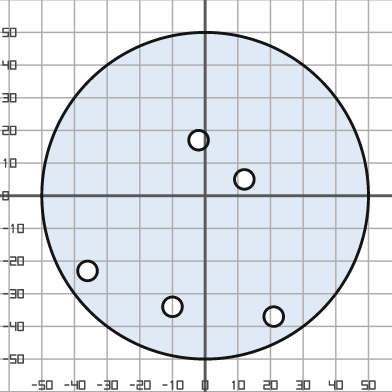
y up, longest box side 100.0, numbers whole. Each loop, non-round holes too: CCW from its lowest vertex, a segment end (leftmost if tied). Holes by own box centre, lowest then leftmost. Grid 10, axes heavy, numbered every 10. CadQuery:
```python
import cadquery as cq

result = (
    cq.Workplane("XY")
    .moveTo(0.0, 0.0)
    .circle(50.0)
    .moveTo(21.0, -37.0)
    .circle(3.0)
    .moveTo(-10.0, -34.0)
    .circle(3.0)
    .moveTo(-36.0, -23.0)
    .circle(3.0)
    .moveTo(12.0, 5.0)
    .circle(3.0)
    .moveTo(-2.0, 17.0)
    .circle(3.0)
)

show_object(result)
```